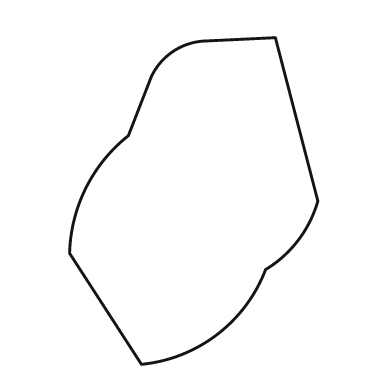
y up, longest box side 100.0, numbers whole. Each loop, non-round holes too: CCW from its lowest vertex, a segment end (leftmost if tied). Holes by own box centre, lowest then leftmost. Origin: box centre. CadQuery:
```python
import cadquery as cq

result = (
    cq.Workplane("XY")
    .moveTo(-16.0, -50.0)
    .threePointArc((7.0, -41.0), (22.0, -21.0))
    .threePointArc((32.0, -12.0), (38.0, 0.0))
    .lineTo(25.0, 50.0)
    .lineTo(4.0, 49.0)
    .threePointArc((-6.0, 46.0), (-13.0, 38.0))
    .lineTo(-20.0, 20.0)
    .threePointArc((-33.0, 4.0), (-38.0, -16.0))
    .close()
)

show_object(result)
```